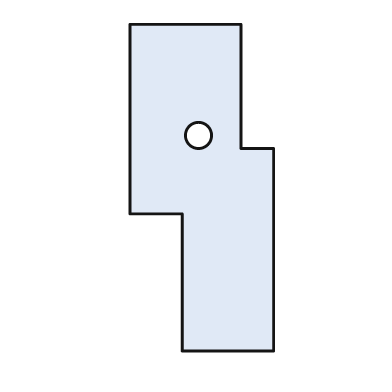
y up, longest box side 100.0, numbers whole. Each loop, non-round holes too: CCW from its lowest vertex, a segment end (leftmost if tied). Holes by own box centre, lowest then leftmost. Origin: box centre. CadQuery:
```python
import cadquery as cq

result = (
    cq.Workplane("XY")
    .moveTo(-6.0, -50.0)
    .lineTo(22.0, -50.0)
    .lineTo(22.0, 12.0)
    .lineTo(12.0, 12.0)
    .lineTo(12.0, 50.0)
    .lineTo(-22.0, 50.0)
    .lineTo(-22.0, -8.0)
    .lineTo(-6.0, -8.0)
    .close()
    .moveTo(-1.0, 16.0)
    .circle(4.0)
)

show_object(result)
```